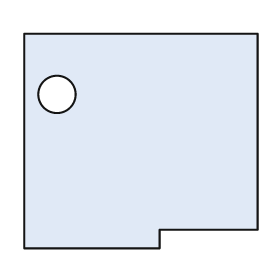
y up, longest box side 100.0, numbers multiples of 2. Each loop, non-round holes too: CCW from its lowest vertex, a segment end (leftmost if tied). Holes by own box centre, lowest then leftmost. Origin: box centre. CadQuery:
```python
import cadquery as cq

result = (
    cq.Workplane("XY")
    .moveTo(-50.0, -46.0)
    .lineTo(8.0, -46.0)
    .lineTo(8.0, -38.0)
    .lineTo(50.0, -38.0)
    .lineTo(50.0, 46.0)
    .lineTo(-50.0, 46.0)
    .close()
    .moveTo(-36.0, 20.0)
    .circle(8.0)
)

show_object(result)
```